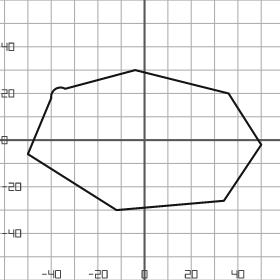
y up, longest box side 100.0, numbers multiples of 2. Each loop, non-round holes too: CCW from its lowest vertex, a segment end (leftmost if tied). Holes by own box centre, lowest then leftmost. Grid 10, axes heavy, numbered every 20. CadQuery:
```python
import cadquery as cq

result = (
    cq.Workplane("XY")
    .moveTo(-12.0, -30.0)
    .lineTo(34.0, -26.0)
    .lineTo(50.0, -2.0)
    .lineTo(36.0, 20.0)
    .lineTo(-4.0, 30.0)
    .lineTo(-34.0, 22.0)
    .threePointArc((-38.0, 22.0), (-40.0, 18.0))
    .lineTo(-50.0, -6.0)
    .close()
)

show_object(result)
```